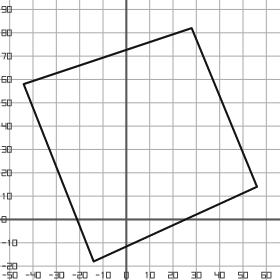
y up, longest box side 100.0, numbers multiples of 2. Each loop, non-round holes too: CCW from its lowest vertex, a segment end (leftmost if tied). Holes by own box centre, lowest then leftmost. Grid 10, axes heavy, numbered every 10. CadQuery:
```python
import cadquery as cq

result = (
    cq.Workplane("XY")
    .moveTo(-14.0, -18.0)
    .lineTo(56.0, 14.0)
    .lineTo(28.0, 82.0)
    .lineTo(-44.0, 58.0)
    .close()
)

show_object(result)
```